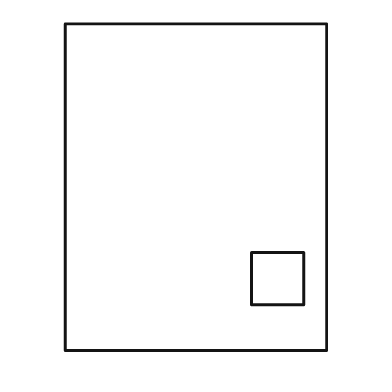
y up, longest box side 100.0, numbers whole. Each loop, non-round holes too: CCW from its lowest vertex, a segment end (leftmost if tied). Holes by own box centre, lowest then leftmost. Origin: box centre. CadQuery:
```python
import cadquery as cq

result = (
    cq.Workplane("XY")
    .moveTo(-40.0, -50.0)
    .lineTo(40.0, -50.0)
    .lineTo(40.0, 50.0)
    .lineTo(-40.0, 50.0)
    .close()
    .moveTo(17.0, -36.0)
    .lineTo(33.0, -36.0)
    .lineTo(33.0, -20.0)
    .lineTo(17.0, -20.0)
    .close()
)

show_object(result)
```